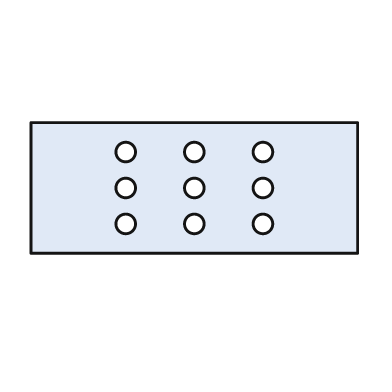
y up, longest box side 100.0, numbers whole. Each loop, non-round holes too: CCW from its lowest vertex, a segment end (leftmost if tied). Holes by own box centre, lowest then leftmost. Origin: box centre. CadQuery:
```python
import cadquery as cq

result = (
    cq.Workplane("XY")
    .moveTo(-50.0, -20.0)
    .lineTo(50.0, -20.0)
    .lineTo(50.0, 20.0)
    .lineTo(-50.0, 20.0)
    .close()
    .moveTo(-21.0, -11.0)
    .circle(3.0)
    .moveTo(0.0, -11.0)
    .circle(3.0)
    .moveTo(21.0, -11.0)
    .circle(3.0)
    .moveTo(-21.0, 0.0)
    .circle(3.0)
    .moveTo(0.0, 0.0)
    .circle(3.0)
    .moveTo(21.0, 0.0)
    .circle(3.0)
    .moveTo(-21.0, 11.0)
    .circle(3.0)
    .moveTo(0.0, 11.0)
    .circle(3.0)
    .moveTo(21.0, 11.0)
    .circle(3.0)
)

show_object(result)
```